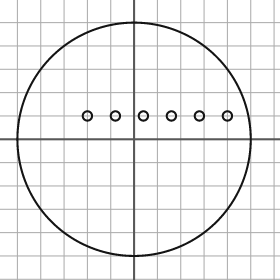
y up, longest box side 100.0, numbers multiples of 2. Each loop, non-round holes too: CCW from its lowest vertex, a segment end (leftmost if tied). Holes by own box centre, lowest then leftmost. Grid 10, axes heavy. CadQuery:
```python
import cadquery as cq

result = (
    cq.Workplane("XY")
    .moveTo(0.0, 0.0)
    .circle(50.0)
    .moveTo(-20.0, 10.0)
    .circle(2.0)
    .moveTo(-8.0, 10.0)
    .circle(2.0)
    .moveTo(4.0, 10.0)
    .circle(2.0)
    .moveTo(16.0, 10.0)
    .circle(2.0)
    .moveTo(28.0, 10.0)
    .circle(2.0)
    .moveTo(40.0, 10.0)
    .circle(2.0)
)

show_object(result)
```